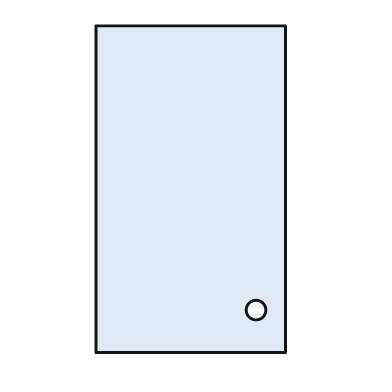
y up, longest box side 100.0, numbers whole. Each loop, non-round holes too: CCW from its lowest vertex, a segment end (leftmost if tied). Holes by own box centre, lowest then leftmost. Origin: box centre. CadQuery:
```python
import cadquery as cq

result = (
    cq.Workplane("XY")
    .moveTo(-29.0, -50.0)
    .lineTo(29.0, -50.0)
    .lineTo(29.0, 50.0)
    .lineTo(-29.0, 50.0)
    .close()
    .moveTo(20.0, -37.0)
    .circle(3.0)
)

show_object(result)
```